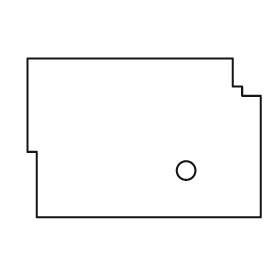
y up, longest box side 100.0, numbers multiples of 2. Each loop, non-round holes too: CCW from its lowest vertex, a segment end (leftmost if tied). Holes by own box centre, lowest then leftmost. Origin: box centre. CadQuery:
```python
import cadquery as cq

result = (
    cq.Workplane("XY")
    .moveTo(-46.0, -34.0)
    .lineTo(50.0, -34.0)
    .lineTo(50.0, 18.0)
    .lineTo(42.0, 18.0)
    .lineTo(42.0, 22.0)
    .lineTo(38.0, 22.0)
    .lineTo(38.0, 34.0)
    .lineTo(-50.0, 34.0)
    .lineTo(-50.0, -6.0)
    .lineTo(-46.0, -6.0)
    .close()
    .moveTo(18.0, -14.0)
    .circle(4.0)
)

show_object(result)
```